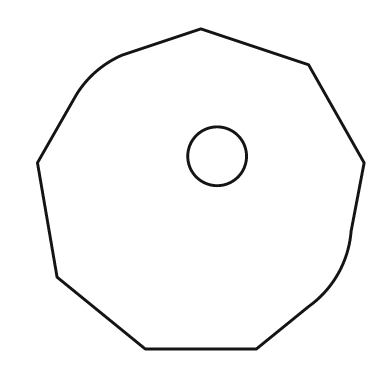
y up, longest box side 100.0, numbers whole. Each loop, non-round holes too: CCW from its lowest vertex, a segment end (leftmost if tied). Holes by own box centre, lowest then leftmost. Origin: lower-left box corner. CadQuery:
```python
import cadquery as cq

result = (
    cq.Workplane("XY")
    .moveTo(33.0, 0.0)
    .lineTo(67.0, 0.0)
    .lineTo(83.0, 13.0)
    .threePointArc((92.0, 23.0), (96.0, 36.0))
    .lineTo(100.0, 57.0)
    .lineTo(83.0, 87.0)
    .lineTo(50.0, 98.0)
    .lineTo(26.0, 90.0)
    .threePointArc((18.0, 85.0), (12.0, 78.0))
    .lineTo(0.0, 57.0)
    .lineTo(6.0, 22.0)
    .close()
    .moveTo(55.0, 59.0)
    .circle(9.0)
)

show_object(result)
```